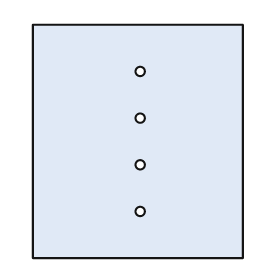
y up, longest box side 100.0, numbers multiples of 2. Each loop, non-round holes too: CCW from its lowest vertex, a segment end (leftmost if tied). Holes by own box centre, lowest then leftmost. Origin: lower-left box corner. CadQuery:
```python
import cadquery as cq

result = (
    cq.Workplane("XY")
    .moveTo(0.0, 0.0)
    .lineTo(90.0, 0.0)
    .lineTo(90.0, 100.0)
    .lineTo(0.0, 100.0)
    .close()
    .moveTo(46.0, 20.0)
    .circle(2.0)
    .moveTo(46.0, 40.0)
    .circle(2.0)
    .moveTo(46.0, 60.0)
    .circle(2.0)
    .moveTo(46.0, 80.0)
    .circle(2.0)
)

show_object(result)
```